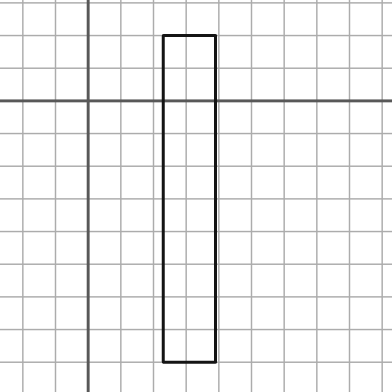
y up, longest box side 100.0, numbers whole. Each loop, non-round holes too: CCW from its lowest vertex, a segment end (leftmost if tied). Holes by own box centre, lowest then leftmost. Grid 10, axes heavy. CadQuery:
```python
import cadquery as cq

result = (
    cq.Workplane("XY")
    .moveTo(23.0, -80.0)
    .lineTo(39.0, -80.0)
    .lineTo(39.0, 20.0)
    .lineTo(23.0, 20.0)
    .close()
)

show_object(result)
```